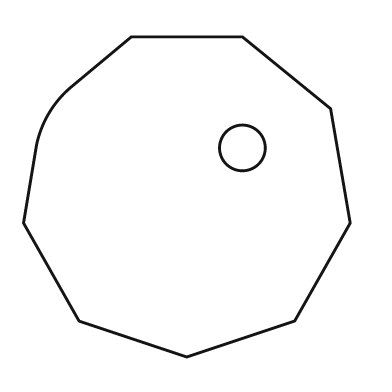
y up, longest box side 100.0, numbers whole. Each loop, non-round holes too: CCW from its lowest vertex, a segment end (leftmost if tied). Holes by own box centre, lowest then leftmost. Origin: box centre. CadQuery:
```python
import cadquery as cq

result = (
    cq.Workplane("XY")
    .moveTo(0.0, -49.0)
    .lineTo(33.0, -38.0)
    .lineTo(50.0, -8.0)
    .lineTo(44.0, 27.0)
    .lineTo(17.0, 49.0)
    .lineTo(-17.0, 49.0)
    .lineTo(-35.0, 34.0)
    .threePointArc((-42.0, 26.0), (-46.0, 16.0))
    .lineTo(-50.0, -8.0)
    .lineTo(-33.0, -38.0)
    .close()
    .moveTo(17.0, 15.0)
    .circle(7.0)
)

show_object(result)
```